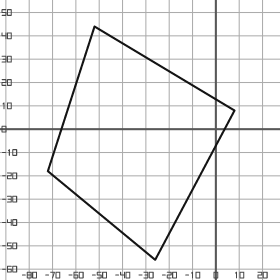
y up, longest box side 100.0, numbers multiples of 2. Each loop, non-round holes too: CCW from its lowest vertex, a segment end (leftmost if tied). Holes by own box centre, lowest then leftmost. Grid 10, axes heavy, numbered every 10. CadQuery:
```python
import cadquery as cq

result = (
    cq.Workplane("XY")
    .moveTo(-26.0, -56.0)
    .lineTo(8.0, 8.0)
    .lineTo(-52.0, 44.0)
    .lineTo(-72.0, -18.0)
    .close()
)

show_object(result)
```